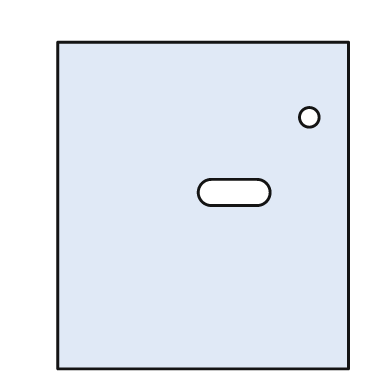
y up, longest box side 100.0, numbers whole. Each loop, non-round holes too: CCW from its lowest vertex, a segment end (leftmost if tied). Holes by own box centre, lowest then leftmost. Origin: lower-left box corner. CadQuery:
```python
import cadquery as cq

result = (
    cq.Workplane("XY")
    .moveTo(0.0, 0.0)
    .lineTo(89.0, 0.0)
    .lineTo(89.0, 100.0)
    .lineTo(0.0, 100.0)
    .close()
    .moveTo(47.0, 50.0)
    .lineTo(61.0, 50.0)
    .threePointArc((65.0, 54.0), (61.0, 58.0))
    .lineTo(47.0, 58.0)
    .threePointArc((43.0, 54.0), (47.0, 50.0))
    .close()
    .moveTo(77.0, 77.0)
    .circle(3.0)
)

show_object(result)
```